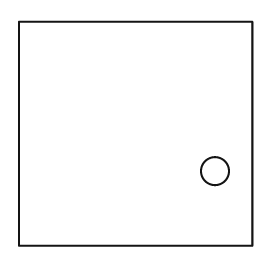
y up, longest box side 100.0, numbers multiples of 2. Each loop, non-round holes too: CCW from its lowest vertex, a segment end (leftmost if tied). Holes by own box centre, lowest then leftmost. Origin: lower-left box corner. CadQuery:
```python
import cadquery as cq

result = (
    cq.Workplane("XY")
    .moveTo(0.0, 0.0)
    .lineTo(100.0, 0.0)
    .lineTo(100.0, 96.0)
    .lineTo(0.0, 96.0)
    .close()
    .moveTo(84.0, 32.0)
    .circle(6.0)
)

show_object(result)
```